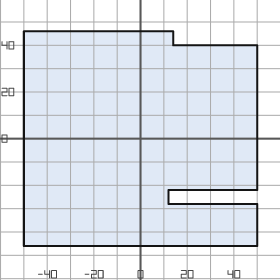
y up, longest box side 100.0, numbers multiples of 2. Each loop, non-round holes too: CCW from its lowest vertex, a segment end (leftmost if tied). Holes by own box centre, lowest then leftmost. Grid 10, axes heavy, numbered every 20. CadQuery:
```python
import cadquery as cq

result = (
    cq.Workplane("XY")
    .moveTo(-50.0, -46.0)
    .lineTo(50.0, -46.0)
    .lineTo(50.0, -28.0)
    .lineTo(12.0, -28.0)
    .lineTo(12.0, -22.0)
    .lineTo(50.0, -22.0)
    .lineTo(50.0, 40.0)
    .lineTo(14.0, 40.0)
    .lineTo(14.0, 46.0)
    .lineTo(-50.0, 46.0)
    .close()
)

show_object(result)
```